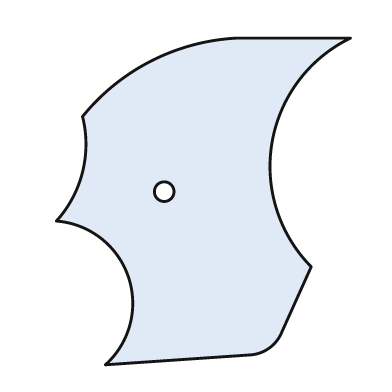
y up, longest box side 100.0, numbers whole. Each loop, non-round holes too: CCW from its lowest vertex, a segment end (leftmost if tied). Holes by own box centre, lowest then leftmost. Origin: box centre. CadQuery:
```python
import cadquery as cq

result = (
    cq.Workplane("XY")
    .moveTo(-30.0, -50.0)
    .lineTo(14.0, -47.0)
    .threePointArc((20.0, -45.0), (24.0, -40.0))
    .lineTo(33.0, -20.0)
    .threePointArc((21.0, 18.0), (45.0, 50.0))
    .lineTo(10.0, 50.0)
    .threePointArc((-16.0, 43.0), (-37.0, 26.0))
    .threePointArc((-37.0, 9.0), (-45.0, -6.0))
    .threePointArc((-23.0, -23.0), (-30.0, -50.0))
    .close()
    .moveTo(-12.0, 3.0)
    .circle(3.0)
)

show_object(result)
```